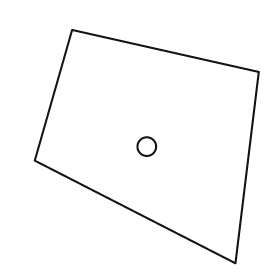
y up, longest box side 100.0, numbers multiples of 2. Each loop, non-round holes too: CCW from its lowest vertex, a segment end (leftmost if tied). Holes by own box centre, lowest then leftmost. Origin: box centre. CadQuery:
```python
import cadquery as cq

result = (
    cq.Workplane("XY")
    .moveTo(38.0, -50.0)
    .lineTo(48.0, 32.0)
    .lineTo(-32.0, 50.0)
    .lineTo(-48.0, -6.0)
    .close()
    .moveTo(0.0, 0.0)
    .circle(4.0)
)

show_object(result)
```